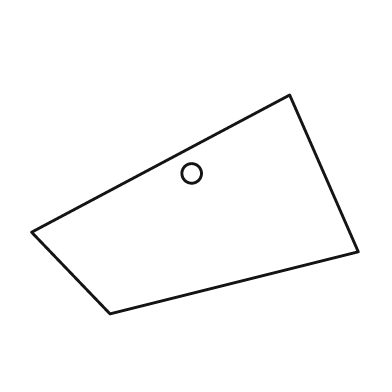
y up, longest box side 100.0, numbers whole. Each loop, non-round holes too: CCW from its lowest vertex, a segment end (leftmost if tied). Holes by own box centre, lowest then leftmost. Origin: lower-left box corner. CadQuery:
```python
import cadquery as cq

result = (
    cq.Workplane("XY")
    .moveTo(24.0, 0.0)
    .lineTo(100.0, 19.0)
    .lineTo(79.0, 67.0)
    .lineTo(0.0, 25.0)
    .close()
    .moveTo(49.0, 43.0)
    .circle(3.0)
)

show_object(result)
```